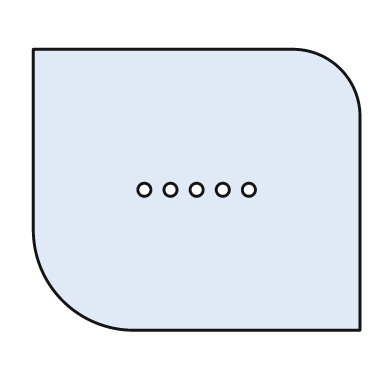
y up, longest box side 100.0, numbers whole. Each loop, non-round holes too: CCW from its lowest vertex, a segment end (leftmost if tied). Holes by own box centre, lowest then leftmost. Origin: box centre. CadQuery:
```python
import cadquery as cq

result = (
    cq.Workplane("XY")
    .moveTo(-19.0, -43.0)
    .lineTo(50.0, -43.0)
    .lineTo(50.0, 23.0)
    .threePointArc((44.0, 37.0), (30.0, 43.0))
    .lineTo(-50.0, 43.0)
    .lineTo(-50.0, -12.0)
    .threePointArc((-41.0, -34.0), (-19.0, -43.0))
    .close()
    .moveTo(-16.0, 0.0)
    .circle(2.0)
    .moveTo(-8.0, 0.0)
    .circle(2.0)
    .moveTo(0.0, 0.0)
    .circle(2.0)
    .moveTo(8.0, 0.0)
    .circle(2.0)
    .moveTo(16.0, 0.0)
    .circle(2.0)
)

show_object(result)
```